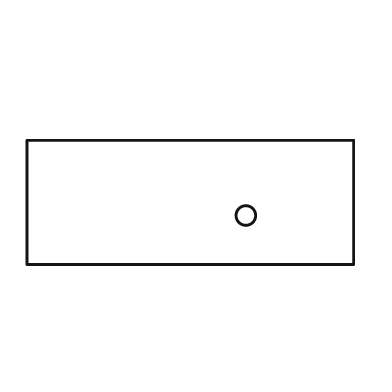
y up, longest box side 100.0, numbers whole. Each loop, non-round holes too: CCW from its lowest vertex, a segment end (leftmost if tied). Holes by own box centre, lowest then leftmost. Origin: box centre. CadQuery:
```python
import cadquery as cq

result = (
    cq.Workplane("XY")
    .moveTo(-50.0, -19.0)
    .lineTo(50.0, -19.0)
    .lineTo(50.0, 19.0)
    .lineTo(-50.0, 19.0)
    .close()
    .moveTo(17.0, -4.0)
    .circle(3.0)
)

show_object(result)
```